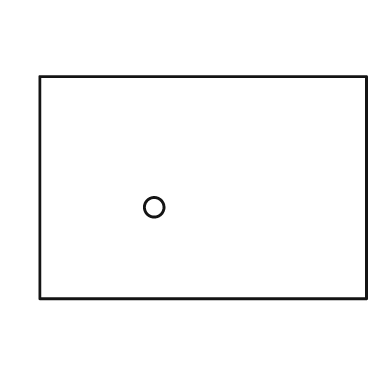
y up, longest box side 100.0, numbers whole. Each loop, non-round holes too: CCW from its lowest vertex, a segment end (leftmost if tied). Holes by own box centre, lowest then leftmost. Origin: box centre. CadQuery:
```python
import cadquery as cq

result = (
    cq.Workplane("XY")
    .moveTo(-50.0, -34.0)
    .lineTo(50.0, -34.0)
    .lineTo(50.0, 34.0)
    .lineTo(-50.0, 34.0)
    .close()
    .moveTo(-15.0, -6.0)
    .circle(3.0)
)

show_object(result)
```